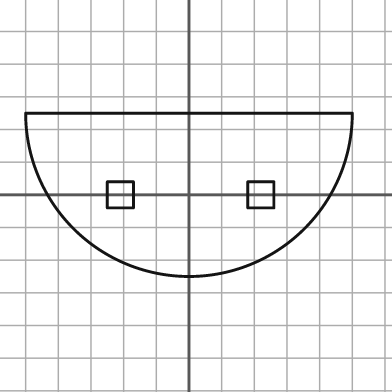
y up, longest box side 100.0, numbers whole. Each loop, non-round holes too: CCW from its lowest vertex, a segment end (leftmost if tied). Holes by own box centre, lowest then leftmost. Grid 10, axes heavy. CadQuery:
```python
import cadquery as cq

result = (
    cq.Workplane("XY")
    .moveTo(-50.0, 25.0)
    .threePointArc((0.0, -25.0), (50.0, 25.0))
    .close()
    .moveTo(-25.0, -4.0)
    .lineTo(-17.0, -4.0)
    .lineTo(-17.0, 4.0)
    .lineTo(-25.0, 4.0)
    .close()
    .moveTo(18.0, -4.0)
    .lineTo(26.0, -4.0)
    .lineTo(26.0, 4.0)
    .lineTo(18.0, 4.0)
    .close()
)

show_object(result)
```